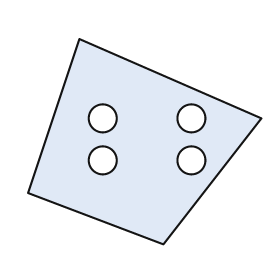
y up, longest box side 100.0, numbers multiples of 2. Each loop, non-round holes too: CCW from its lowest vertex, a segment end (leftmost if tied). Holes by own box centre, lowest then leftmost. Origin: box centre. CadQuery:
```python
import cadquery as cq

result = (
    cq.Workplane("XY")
    .moveTo(8.0, -44.0)
    .lineTo(50.0, 10.0)
    .lineTo(-28.0, 44.0)
    .lineTo(-50.0, -22.0)
    .close()
    .moveTo(-18.0, -8.0)
    .circle(6.0)
    .moveTo(20.0, -8.0)
    .circle(6.0)
    .moveTo(-18.0, 10.0)
    .circle(6.0)
    .moveTo(20.0, 10.0)
    .circle(6.0)
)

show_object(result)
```